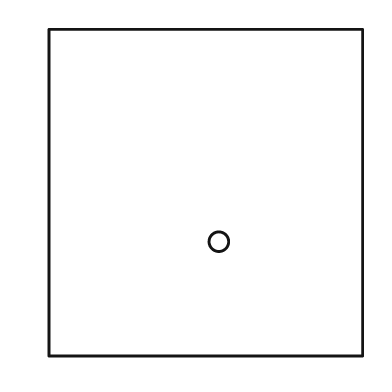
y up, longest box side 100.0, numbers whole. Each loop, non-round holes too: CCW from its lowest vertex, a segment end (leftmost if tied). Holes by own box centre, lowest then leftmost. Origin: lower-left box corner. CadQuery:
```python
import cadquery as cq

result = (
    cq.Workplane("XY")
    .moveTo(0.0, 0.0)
    .lineTo(96.0, 0.0)
    .lineTo(96.0, 100.0)
    .lineTo(0.0, 100.0)
    .close()
    .moveTo(52.0, 35.0)
    .circle(3.0)
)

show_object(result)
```